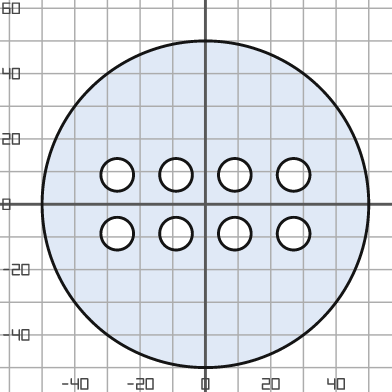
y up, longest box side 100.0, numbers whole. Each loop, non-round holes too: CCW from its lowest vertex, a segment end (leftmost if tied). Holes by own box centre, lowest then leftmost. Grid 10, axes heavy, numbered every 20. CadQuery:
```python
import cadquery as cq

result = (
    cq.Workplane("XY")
    .moveTo(0.0, 0.0)
    .circle(50.0)
    .moveTo(-27.0, -9.0)
    .circle(5.0)
    .moveTo(-9.0, -9.0)
    .circle(5.0)
    .moveTo(9.0, -9.0)
    .circle(5.0)
    .moveTo(27.0, -9.0)
    .circle(5.0)
    .moveTo(-27.0, 9.0)
    .circle(5.0)
    .moveTo(-9.0, 9.0)
    .circle(5.0)
    .moveTo(9.0, 9.0)
    .circle(5.0)
    .moveTo(27.0, 9.0)
    .circle(5.0)
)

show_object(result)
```